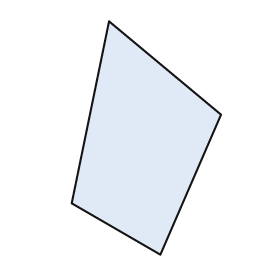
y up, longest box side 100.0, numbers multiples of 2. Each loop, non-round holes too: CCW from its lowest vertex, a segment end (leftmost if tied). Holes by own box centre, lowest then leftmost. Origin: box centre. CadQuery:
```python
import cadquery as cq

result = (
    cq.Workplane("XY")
    .moveTo(6.0, -50.0)
    .lineTo(32.0, 10.0)
    .lineTo(-16.0, 50.0)
    .lineTo(-32.0, -28.0)
    .close()
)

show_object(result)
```